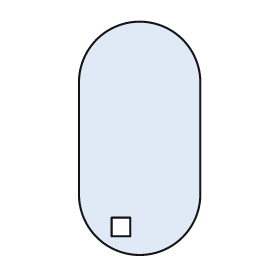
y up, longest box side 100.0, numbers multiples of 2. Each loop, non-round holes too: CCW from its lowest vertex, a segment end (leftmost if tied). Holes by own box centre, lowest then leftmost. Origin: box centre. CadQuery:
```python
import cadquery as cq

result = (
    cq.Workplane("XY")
    .moveTo(-26.0, -24.0)
    .threePointArc((0.0, -50.0), (26.0, -24.0))
    .lineTo(26.0, 24.0)
    .threePointArc((0.0, 50.0), (-26.0, 24.0))
    .close()
    .moveTo(-12.0, -42.0)
    .lineTo(-4.0, -42.0)
    .lineTo(-4.0, -34.0)
    .lineTo(-12.0, -34.0)
    .close()
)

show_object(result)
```